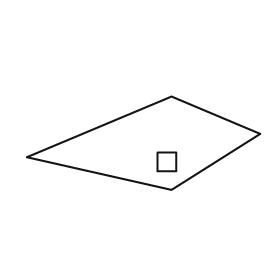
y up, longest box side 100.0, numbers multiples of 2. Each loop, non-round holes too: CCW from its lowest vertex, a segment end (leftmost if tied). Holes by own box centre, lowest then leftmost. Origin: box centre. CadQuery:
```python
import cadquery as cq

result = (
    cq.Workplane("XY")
    .moveTo(12.0, -20.0)
    .lineTo(50.0, 4.0)
    .lineTo(12.0, 20.0)
    .lineTo(-50.0, -6.0)
    .close()
    .moveTo(6.0, -12.0)
    .lineTo(14.0, -12.0)
    .lineTo(14.0, -4.0)
    .lineTo(6.0, -4.0)
    .close()
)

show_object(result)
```